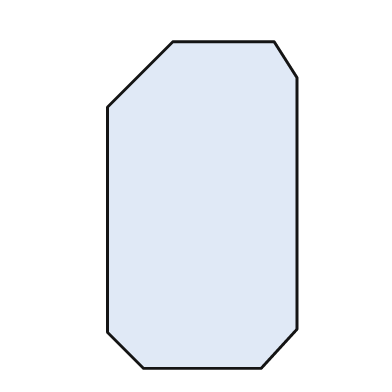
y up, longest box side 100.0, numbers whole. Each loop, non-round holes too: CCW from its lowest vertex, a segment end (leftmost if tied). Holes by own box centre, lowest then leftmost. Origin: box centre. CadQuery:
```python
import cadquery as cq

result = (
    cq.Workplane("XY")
    .moveTo(-18.0, -50.0)
    .lineTo(18.0, -50.0)
    .lineTo(29.0, -38.0)
    .lineTo(29.0, 39.0)
    .lineTo(22.0, 50.0)
    .lineTo(-9.0, 50.0)
    .lineTo(-29.0, 30.0)
    .lineTo(-29.0, -39.0)
    .close()
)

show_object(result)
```